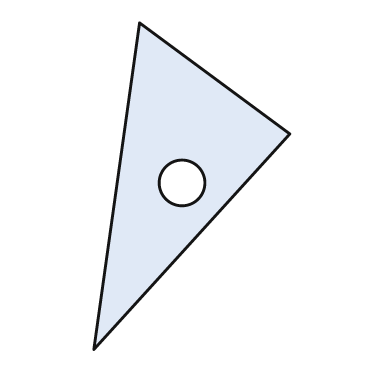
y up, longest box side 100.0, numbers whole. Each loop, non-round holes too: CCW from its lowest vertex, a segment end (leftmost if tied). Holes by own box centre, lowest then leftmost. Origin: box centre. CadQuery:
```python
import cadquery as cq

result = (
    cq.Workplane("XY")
    .moveTo(-30.0, -50.0)
    .lineTo(30.0, 16.0)
    .lineTo(-16.0, 50.0)
    .close()
    .moveTo(-3.0, 1.0)
    .circle(7.0)
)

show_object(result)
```